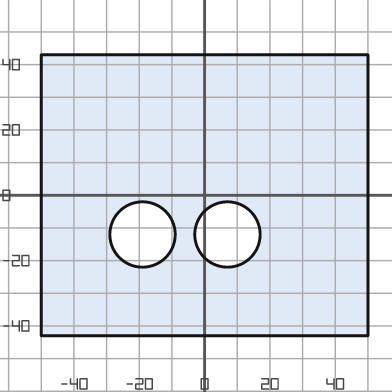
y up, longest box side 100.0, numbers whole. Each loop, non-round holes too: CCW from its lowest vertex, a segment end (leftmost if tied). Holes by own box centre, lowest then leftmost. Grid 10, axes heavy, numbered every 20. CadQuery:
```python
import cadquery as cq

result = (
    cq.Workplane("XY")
    .moveTo(-50.0, -43.0)
    .lineTo(50.0, -43.0)
    .lineTo(50.0, 43.0)
    .lineTo(-50.0, 43.0)
    .close()
    .moveTo(-19.0, -12.0)
    .circle(10.0)
    .moveTo(7.0, -12.0)
    .circle(10.0)
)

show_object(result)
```